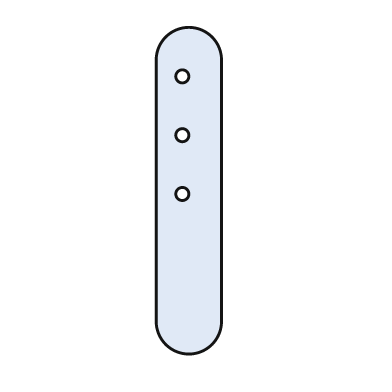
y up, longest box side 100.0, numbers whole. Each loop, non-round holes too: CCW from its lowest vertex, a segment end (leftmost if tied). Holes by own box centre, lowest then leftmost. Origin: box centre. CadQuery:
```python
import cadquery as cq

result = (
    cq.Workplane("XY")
    .moveTo(-10.0, -40.0)
    .threePointArc((0.0, -50.0), (10.0, -40.0))
    .lineTo(10.0, 40.0)
    .threePointArc((0.0, 50.0), (-10.0, 40.0))
    .close()
    .moveTo(-2.0, -1.0)
    .circle(2.0)
    .moveTo(-2.0, 17.0)
    .circle(2.0)
    .moveTo(-2.0, 35.0)
    .circle(2.0)
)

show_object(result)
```